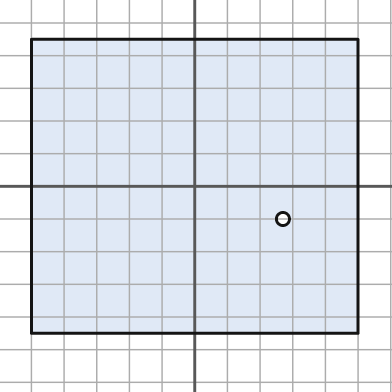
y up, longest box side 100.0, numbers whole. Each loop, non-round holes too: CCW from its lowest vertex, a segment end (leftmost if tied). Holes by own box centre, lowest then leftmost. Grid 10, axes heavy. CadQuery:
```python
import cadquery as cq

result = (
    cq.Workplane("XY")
    .moveTo(-50.0, -45.0)
    .lineTo(50.0, -45.0)
    .lineTo(50.0, 45.0)
    .lineTo(-50.0, 45.0)
    .close()
    .moveTo(27.0, -10.0)
    .circle(2.0)
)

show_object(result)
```